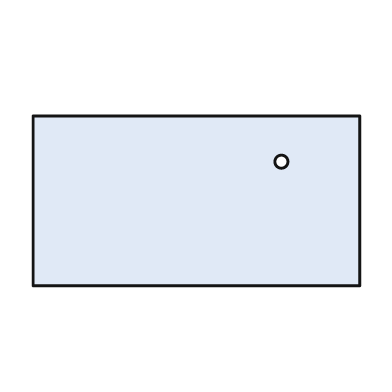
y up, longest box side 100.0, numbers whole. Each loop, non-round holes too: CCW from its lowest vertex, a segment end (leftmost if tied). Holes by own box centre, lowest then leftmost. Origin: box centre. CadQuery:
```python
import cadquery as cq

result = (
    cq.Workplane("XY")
    .moveTo(-50.0, -26.0)
    .lineTo(50.0, -26.0)
    .lineTo(50.0, 26.0)
    .lineTo(-50.0, 26.0)
    .close()
    .moveTo(26.0, 12.0)
    .circle(2.0)
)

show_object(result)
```